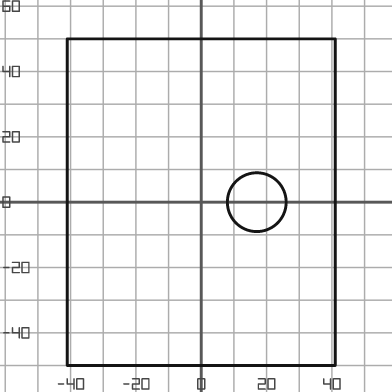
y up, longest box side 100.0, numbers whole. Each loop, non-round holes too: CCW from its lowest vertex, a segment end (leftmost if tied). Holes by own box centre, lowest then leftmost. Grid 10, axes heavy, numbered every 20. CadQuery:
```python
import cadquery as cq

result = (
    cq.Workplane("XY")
    .moveTo(-41.0, -50.0)
    .lineTo(41.0, -50.0)
    .lineTo(41.0, 50.0)
    .lineTo(-41.0, 50.0)
    .close()
    .moveTo(17.0, 0.0)
    .circle(9.0)
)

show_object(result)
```